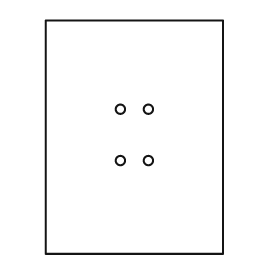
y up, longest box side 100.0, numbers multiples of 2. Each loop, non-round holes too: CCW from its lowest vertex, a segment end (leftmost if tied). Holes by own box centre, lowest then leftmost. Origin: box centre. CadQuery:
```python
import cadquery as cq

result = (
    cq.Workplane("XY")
    .moveTo(-38.0, -50.0)
    .lineTo(38.0, -50.0)
    .lineTo(38.0, 50.0)
    .lineTo(-38.0, 50.0)
    .close()
    .moveTo(-6.0, -10.0)
    .circle(2.0)
    .moveTo(6.0, -10.0)
    .circle(2.0)
    .moveTo(-6.0, 12.0)
    .circle(2.0)
    .moveTo(6.0, 12.0)
    .circle(2.0)
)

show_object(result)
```